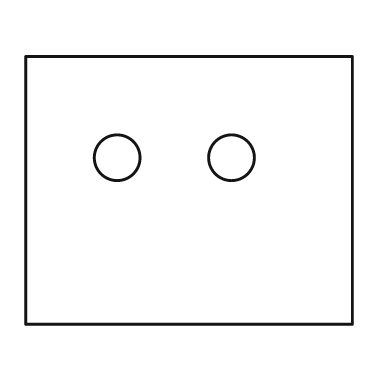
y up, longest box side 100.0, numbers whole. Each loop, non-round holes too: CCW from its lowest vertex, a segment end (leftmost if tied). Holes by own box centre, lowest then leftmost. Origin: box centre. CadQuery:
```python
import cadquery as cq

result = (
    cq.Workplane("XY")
    .moveTo(-50.0, -41.0)
    .lineTo(50.0, -41.0)
    .lineTo(50.0, 41.0)
    .lineTo(-50.0, 41.0)
    .close()
    .moveTo(-22.0, 10.0)
    .circle(7.0)
    .moveTo(13.0, 10.0)
    .circle(7.0)
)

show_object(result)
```